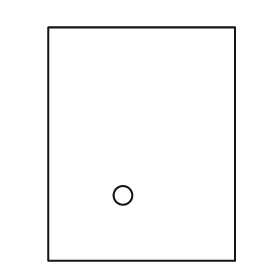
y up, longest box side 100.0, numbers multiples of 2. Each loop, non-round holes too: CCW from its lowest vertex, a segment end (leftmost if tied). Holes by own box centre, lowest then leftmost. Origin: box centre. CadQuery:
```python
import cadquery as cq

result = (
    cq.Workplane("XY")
    .moveTo(-40.0, -50.0)
    .lineTo(40.0, -50.0)
    .lineTo(40.0, 50.0)
    .lineTo(-40.0, 50.0)
    .close()
    .moveTo(-8.0, -22.0)
    .circle(4.0)
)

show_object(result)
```